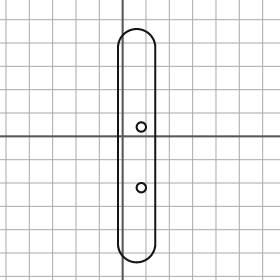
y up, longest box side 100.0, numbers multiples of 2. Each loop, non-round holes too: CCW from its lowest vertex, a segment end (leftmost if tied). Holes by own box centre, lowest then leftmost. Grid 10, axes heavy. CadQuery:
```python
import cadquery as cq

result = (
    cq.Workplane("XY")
    .moveTo(-2.0, -46.0)
    .threePointArc((6.0, -54.0), (14.0, -46.0))
    .lineTo(14.0, 38.0)
    .threePointArc((6.0, 46.0), (-2.0, 38.0))
    .close()
    .moveTo(8.0, -22.0)
    .circle(2.0)
    .moveTo(8.0, 4.0)
    .circle(2.0)
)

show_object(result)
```